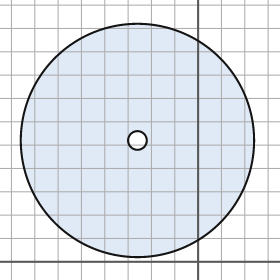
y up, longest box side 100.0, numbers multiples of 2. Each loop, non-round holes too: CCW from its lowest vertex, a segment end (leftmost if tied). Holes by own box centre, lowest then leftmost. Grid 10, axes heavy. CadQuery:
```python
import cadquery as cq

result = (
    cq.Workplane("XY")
    .moveTo(-26.0, 52.0)
    .circle(50.0)
    .moveTo(-26.0, 52.0)
    .circle(4.0)
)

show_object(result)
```